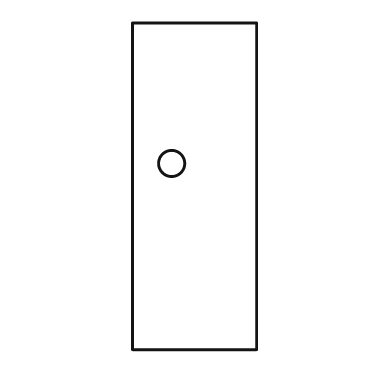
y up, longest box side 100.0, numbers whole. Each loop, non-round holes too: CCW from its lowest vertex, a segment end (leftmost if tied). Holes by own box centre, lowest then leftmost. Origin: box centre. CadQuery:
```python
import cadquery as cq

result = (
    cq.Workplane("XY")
    .moveTo(-19.0, -50.0)
    .lineTo(19.0, -50.0)
    .lineTo(19.0, 50.0)
    .lineTo(-19.0, 50.0)
    .close()
    .moveTo(-7.0, 7.0)
    .circle(4.0)
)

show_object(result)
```